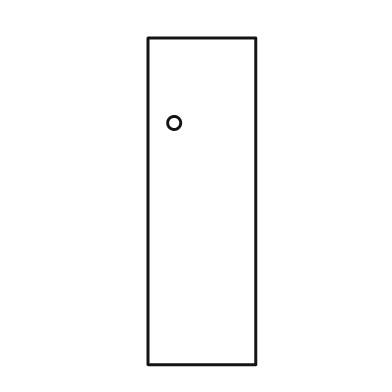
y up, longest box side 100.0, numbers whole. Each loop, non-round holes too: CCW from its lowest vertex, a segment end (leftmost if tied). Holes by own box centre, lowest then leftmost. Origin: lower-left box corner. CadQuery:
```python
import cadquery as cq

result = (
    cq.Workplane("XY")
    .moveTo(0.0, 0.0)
    .lineTo(33.0, 0.0)
    .lineTo(33.0, 100.0)
    .lineTo(0.0, 100.0)
    .close()
    .moveTo(8.0, 74.0)
    .circle(2.0)
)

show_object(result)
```